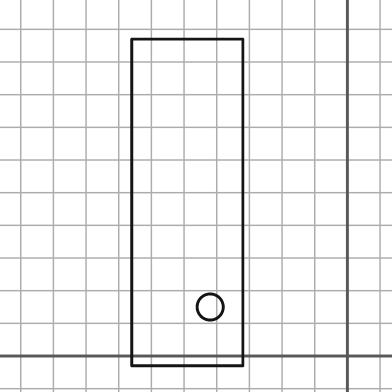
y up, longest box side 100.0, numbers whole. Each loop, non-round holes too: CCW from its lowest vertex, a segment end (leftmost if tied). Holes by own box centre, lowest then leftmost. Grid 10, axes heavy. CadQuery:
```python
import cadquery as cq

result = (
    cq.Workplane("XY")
    .moveTo(-66.0, -3.0)
    .lineTo(-32.0, -3.0)
    .lineTo(-32.0, 97.0)
    .lineTo(-66.0, 97.0)
    .close()
    .moveTo(-42.0, 15.0)
    .circle(4.0)
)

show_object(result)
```